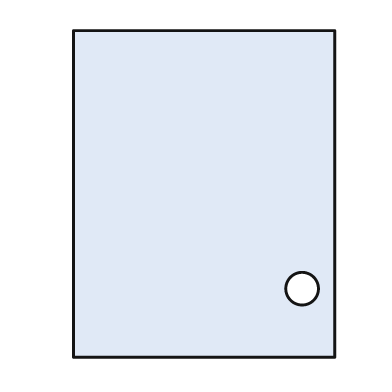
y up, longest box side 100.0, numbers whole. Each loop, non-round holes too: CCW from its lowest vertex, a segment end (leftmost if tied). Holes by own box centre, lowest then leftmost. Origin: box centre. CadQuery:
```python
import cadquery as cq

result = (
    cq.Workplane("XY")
    .moveTo(-40.0, -50.0)
    .lineTo(40.0, -50.0)
    .lineTo(40.0, 50.0)
    .lineTo(-40.0, 50.0)
    .close()
    .moveTo(30.0, -29.0)
    .circle(5.0)
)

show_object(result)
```